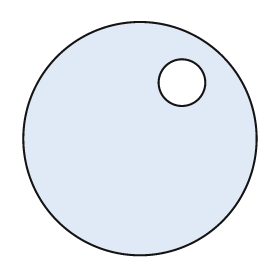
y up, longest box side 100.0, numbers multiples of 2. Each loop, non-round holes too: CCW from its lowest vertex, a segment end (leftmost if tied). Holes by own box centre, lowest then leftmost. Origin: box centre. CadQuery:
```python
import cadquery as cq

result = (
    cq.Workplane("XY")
    .moveTo(0.0, 0.0)
    .circle(50.0)
    .moveTo(18.0, 24.0)
    .circle(10.0)
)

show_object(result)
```